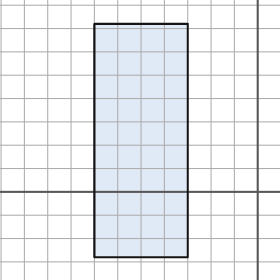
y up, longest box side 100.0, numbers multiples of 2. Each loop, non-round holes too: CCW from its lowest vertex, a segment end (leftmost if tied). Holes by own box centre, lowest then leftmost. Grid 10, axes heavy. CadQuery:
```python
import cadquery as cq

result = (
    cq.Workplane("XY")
    .moveTo(-70.0, -28.0)
    .lineTo(-30.0, -28.0)
    .lineTo(-30.0, 72.0)
    .lineTo(-70.0, 72.0)
    .close()
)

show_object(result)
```